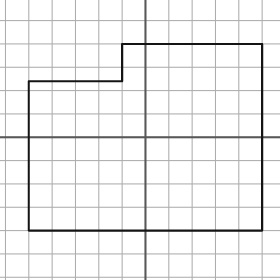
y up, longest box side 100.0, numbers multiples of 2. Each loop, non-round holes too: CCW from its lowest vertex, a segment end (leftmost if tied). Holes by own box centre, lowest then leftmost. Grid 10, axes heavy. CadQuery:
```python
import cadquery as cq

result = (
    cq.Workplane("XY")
    .moveTo(-50.0, -40.0)
    .lineTo(50.0, -40.0)
    .lineTo(50.0, 40.0)
    .lineTo(-10.0, 40.0)
    .lineTo(-10.0, 24.0)
    .lineTo(-50.0, 24.0)
    .close()
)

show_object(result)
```